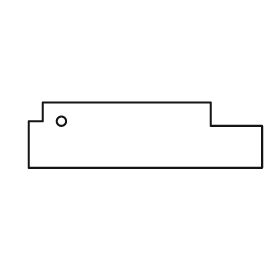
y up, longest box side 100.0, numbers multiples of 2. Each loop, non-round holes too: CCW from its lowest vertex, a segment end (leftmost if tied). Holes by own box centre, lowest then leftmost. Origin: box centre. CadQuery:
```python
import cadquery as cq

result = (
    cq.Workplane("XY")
    .moveTo(-50.0, -14.0)
    .lineTo(50.0, -14.0)
    .lineTo(50.0, 4.0)
    .lineTo(28.0, 4.0)
    .lineTo(28.0, 14.0)
    .lineTo(-44.0, 14.0)
    .lineTo(-44.0, 6.0)
    .lineTo(-50.0, 6.0)
    .close()
    .moveTo(-36.0, 6.0)
    .circle(2.0)
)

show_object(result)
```